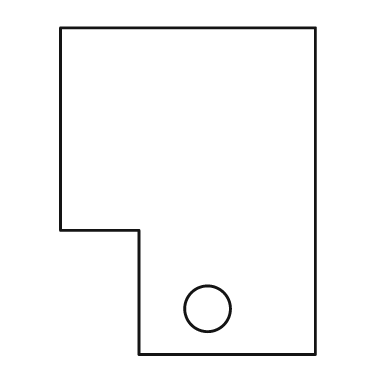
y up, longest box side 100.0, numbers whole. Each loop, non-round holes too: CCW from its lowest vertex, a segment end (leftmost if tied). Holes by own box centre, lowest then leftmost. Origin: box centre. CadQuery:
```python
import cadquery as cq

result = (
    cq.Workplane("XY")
    .moveTo(-15.0, -50.0)
    .lineTo(39.0, -50.0)
    .lineTo(39.0, 50.0)
    .lineTo(-39.0, 50.0)
    .lineTo(-39.0, -12.0)
    .lineTo(-15.0, -12.0)
    .close()
    .moveTo(6.0, -36.0)
    .circle(7.0)
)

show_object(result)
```